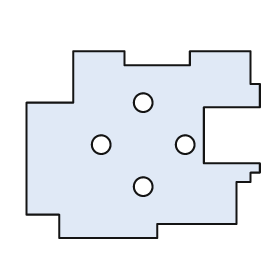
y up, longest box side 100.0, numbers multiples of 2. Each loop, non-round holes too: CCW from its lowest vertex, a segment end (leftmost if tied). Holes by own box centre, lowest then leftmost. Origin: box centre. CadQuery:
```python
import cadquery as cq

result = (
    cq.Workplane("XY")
    .moveTo(-36.0, -40.0)
    .lineTo(6.0, -40.0)
    .lineTo(6.0, -34.0)
    .lineTo(40.0, -34.0)
    .lineTo(40.0, -16.0)
    .lineTo(46.0, -16.0)
    .lineTo(46.0, -12.0)
    .lineTo(50.0, -12.0)
    .lineTo(50.0, -8.0)
    .lineTo(26.0, -8.0)
    .lineTo(26.0, 16.0)
    .lineTo(50.0, 16.0)
    .lineTo(50.0, 26.0)
    .lineTo(46.0, 26.0)
    .lineTo(46.0, 40.0)
    .lineTo(20.0, 40.0)
    .lineTo(20.0, 34.0)
    .lineTo(-8.0, 34.0)
    .lineTo(-8.0, 40.0)
    .lineTo(-30.0, 40.0)
    .lineTo(-30.0, 18.0)
    .lineTo(-50.0, 18.0)
    .lineTo(-50.0, -30.0)
    .lineTo(-36.0, -30.0)
    .close()
    .moveTo(0.0, -18.0)
    .circle(4.0)
    .moveTo(-18.0, 0.0)
    .circle(4.0)
    .moveTo(18.0, 0.0)
    .circle(4.0)
    .moveTo(0.0, 18.0)
    .circle(4.0)
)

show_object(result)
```